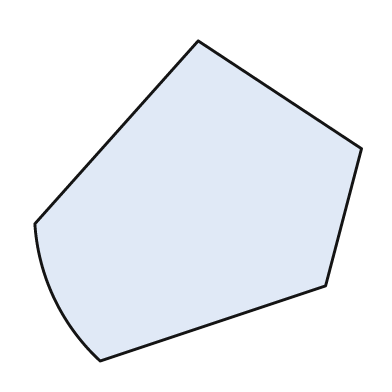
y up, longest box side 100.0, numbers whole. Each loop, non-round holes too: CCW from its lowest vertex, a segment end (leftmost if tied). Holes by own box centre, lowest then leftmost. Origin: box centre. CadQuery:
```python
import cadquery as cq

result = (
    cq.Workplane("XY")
    .moveTo(-30.0, -49.0)
    .lineTo(39.0, -26.0)
    .lineTo(50.0, 16.0)
    .lineTo(0.0, 49.0)
    .lineTo(-50.0, -7.0)
    .threePointArc((-44.0, -30.0), (-30.0, -49.0))
    .close()
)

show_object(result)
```